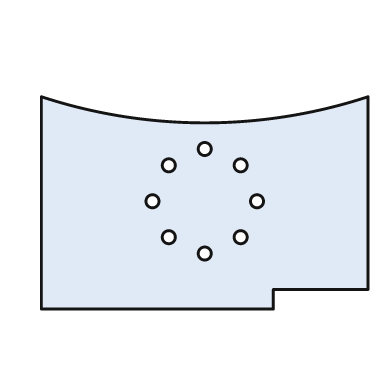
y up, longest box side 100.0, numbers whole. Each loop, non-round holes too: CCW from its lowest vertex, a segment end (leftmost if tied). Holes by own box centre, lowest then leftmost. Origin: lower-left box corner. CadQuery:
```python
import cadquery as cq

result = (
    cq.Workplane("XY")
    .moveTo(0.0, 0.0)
    .lineTo(71.0, 0.0)
    .lineTo(71.0, 6.0)
    .lineTo(100.0, 6.0)
    .lineTo(100.0, 65.0)
    .threePointArc((50.0, 57.0), (0.0, 65.0))
    .close()
    .moveTo(50.0, 17.0)
    .circle(2.0)
    .moveTo(39.0, 22.0)
    .circle(2.0)
    .moveTo(61.0, 22.0)
    .circle(2.0)
    .moveTo(34.0, 33.0)
    .circle(2.0)
    .moveTo(66.0, 33.0)
    .circle(2.0)
    .moveTo(39.0, 44.0)
    .circle(2.0)
    .moveTo(61.0, 44.0)
    .circle(2.0)
    .moveTo(50.0, 49.0)
    .circle(2.0)
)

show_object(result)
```